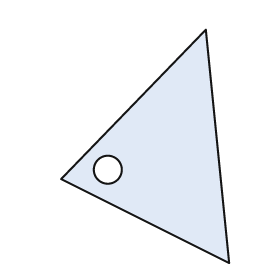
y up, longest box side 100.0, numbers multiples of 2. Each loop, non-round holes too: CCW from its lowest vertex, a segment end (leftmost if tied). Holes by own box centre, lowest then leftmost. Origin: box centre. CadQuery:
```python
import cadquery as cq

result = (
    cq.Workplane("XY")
    .moveTo(36.0, -50.0)
    .lineTo(26.0, 50.0)
    .lineTo(-36.0, -14.0)
    .close()
    .moveTo(-16.0, -10.0)
    .circle(6.0)
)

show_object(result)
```